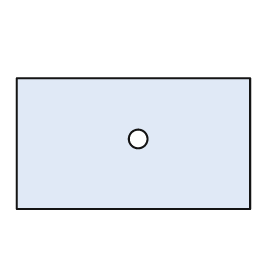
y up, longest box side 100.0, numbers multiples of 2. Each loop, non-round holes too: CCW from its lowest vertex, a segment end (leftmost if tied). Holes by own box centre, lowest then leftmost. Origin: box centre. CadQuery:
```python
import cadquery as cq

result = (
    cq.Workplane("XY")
    .moveTo(-50.0, -28.0)
    .lineTo(50.0, -28.0)
    .lineTo(50.0, 28.0)
    .lineTo(-50.0, 28.0)
    .close()
    .moveTo(2.0, 2.0)
    .circle(4.0)
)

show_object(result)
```